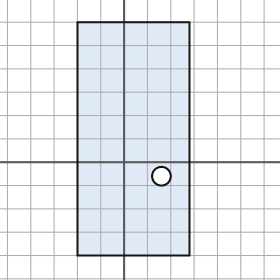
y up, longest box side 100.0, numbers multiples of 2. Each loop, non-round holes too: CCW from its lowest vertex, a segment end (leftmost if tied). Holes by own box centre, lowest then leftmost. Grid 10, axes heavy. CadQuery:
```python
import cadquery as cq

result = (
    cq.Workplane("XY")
    .moveTo(-20.0, -40.0)
    .lineTo(28.0, -40.0)
    .lineTo(28.0, 60.0)
    .lineTo(-20.0, 60.0)
    .close()
    .moveTo(16.0, -6.0)
    .circle(4.0)
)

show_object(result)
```